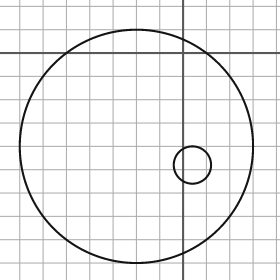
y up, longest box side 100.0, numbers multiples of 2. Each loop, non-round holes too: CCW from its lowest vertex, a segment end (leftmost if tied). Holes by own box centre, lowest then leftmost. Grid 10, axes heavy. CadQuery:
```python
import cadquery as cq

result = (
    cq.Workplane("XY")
    .moveTo(-20.0, -40.0)
    .circle(50.0)
    .moveTo(4.0, -48.0)
    .circle(8.0)
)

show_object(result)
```